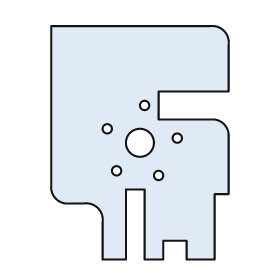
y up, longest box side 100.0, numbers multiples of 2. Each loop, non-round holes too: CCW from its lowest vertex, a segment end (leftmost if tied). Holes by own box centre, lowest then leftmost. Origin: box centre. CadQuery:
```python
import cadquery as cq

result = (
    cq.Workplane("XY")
    .moveTo(-16.0, -50.0)
    .lineTo(-6.0, -50.0)
    .lineTo(-6.0, -20.0)
    .lineTo(2.0, -20.0)
    .lineTo(2.0, -50.0)
    .lineTo(10.0, -50.0)
    .lineTo(10.0, -42.0)
    .lineTo(20.0, -42.0)
    .lineTo(20.0, -50.0)
    .lineTo(32.0, -50.0)
    .lineTo(32.0, -22.0)
    .lineTo(38.0, -22.0)
    .lineTo(38.0, 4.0)
    .threePointArc((36.0, 8.0), (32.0, 10.0))
    .lineTo(8.0, 10.0)
    .lineTo(8.0, 22.0)
    .lineTo(38.0, 22.0)
    .lineTo(38.0, 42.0)
    .threePointArc((36.0, 48.0), (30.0, 50.0))
    .lineTo(-38.0, 50.0)
    .lineTo(-38.0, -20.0)
    .threePointArc((-36.0, -24.0), (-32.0, -26.0))
    .lineTo(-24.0, -26.0)
    .threePointArc((-18.0, -28.0), (-16.0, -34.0))
    .close()
    .moveTo(8.0, -14.0)
    .circle(2.0)
    .moveTo(-10.0, -12.0)
    .circle(2.0)
    .moveTo(0.0, 0.0)
    .circle(6.0)
    .moveTo(16.0, 2.0)
    .circle(2.0)
    .moveTo(-14.0, 6.0)
    .circle(2.0)
    .moveTo(2.0, 16.0)
    .circle(2.0)
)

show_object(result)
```